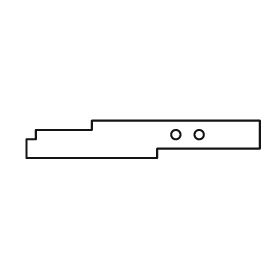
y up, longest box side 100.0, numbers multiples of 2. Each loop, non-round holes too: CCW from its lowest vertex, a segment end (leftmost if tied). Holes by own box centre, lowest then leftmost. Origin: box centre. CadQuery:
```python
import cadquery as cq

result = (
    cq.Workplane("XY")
    .moveTo(-50.0, -8.0)
    .lineTo(6.0, -8.0)
    .lineTo(6.0, -4.0)
    .lineTo(50.0, -4.0)
    .lineTo(50.0, 8.0)
    .lineTo(-22.0, 8.0)
    .lineTo(-22.0, 4.0)
    .lineTo(-46.0, 4.0)
    .lineTo(-46.0, 0.0)
    .lineTo(-50.0, 0.0)
    .close()
    .moveTo(14.0, 2.0)
    .circle(2.0)
    .moveTo(24.0, 2.0)
    .circle(2.0)
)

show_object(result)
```